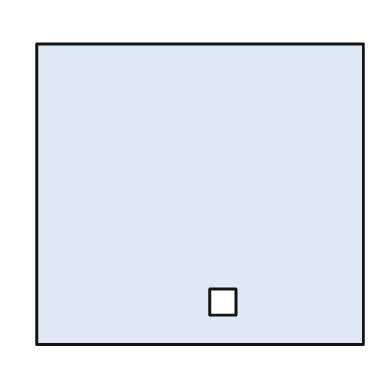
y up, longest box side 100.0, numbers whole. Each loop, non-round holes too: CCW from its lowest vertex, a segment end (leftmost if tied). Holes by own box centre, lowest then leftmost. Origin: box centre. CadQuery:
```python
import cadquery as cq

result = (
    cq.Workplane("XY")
    .moveTo(-50.0, -46.0)
    .lineTo(50.0, -46.0)
    .lineTo(50.0, 46.0)
    .lineTo(-50.0, 46.0)
    .close()
    .moveTo(3.0, -37.0)
    .lineTo(11.0, -37.0)
    .lineTo(11.0, -29.0)
    .lineTo(3.0, -29.0)
    .close()
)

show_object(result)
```